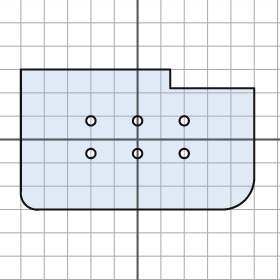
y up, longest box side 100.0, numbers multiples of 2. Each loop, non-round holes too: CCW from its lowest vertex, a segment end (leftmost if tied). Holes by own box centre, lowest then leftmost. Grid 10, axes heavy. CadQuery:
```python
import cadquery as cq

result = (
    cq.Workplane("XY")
    .moveTo(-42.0, -30.0)
    .lineTo(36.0, -30.0)
    .threePointArc((46.0, -26.0), (50.0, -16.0))
    .lineTo(50.0, 22.0)
    .lineTo(14.0, 22.0)
    .lineTo(14.0, 30.0)
    .lineTo(-50.0, 30.0)
    .lineTo(-50.0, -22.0)
    .threePointArc((-48.0, -28.0), (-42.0, -30.0))
    .close()
    .moveTo(-20.0, -6.0)
    .circle(2.0)
    .moveTo(0.0, -6.0)
    .circle(2.0)
    .moveTo(20.0, -6.0)
    .circle(2.0)
    .moveTo(-20.0, 8.0)
    .circle(2.0)
    .moveTo(0.0, 8.0)
    .circle(2.0)
    .moveTo(20.0, 8.0)
    .circle(2.0)
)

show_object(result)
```